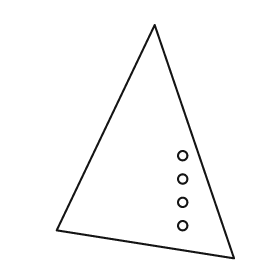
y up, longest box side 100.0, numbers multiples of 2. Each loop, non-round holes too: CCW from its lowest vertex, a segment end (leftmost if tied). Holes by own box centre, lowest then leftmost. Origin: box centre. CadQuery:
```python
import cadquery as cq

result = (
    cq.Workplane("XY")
    .moveTo(38.0, -50.0)
    .lineTo(4.0, 50.0)
    .lineTo(-38.0, -38.0)
    .close()
    .moveTo(16.0, -36.0)
    .circle(2.0)
    .moveTo(16.0, -26.0)
    .circle(2.0)
    .moveTo(16.0, -16.0)
    .circle(2.0)
    .moveTo(16.0, -6.0)
    .circle(2.0)
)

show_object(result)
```